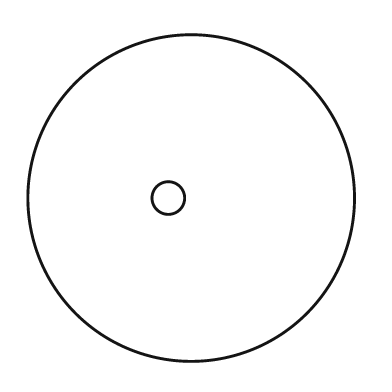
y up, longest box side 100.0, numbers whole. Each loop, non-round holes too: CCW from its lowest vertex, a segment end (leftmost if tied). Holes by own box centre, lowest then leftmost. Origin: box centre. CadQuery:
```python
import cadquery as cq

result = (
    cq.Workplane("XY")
    .moveTo(0.0, 0.0)
    .circle(50.0)
    .moveTo(-7.0, 0.0)
    .circle(5.0)
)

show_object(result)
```